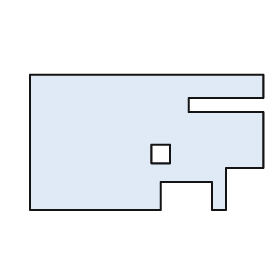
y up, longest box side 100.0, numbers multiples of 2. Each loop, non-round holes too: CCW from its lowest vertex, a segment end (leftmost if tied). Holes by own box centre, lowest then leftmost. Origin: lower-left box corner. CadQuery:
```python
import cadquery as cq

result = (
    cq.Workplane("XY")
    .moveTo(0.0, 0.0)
    .lineTo(56.0, 0.0)
    .lineTo(56.0, 12.0)
    .lineTo(78.0, 12.0)
    .lineTo(78.0, 0.0)
    .lineTo(84.0, 0.0)
    .lineTo(84.0, 18.0)
    .lineTo(100.0, 18.0)
    .lineTo(100.0, 42.0)
    .lineTo(68.0, 42.0)
    .lineTo(68.0, 48.0)
    .lineTo(100.0, 48.0)
    .lineTo(100.0, 58.0)
    .lineTo(0.0, 58.0)
    .close()
    .moveTo(52.0, 20.0)
    .lineTo(60.0, 20.0)
    .lineTo(60.0, 28.0)
    .lineTo(52.0, 28.0)
    .close()
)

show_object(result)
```